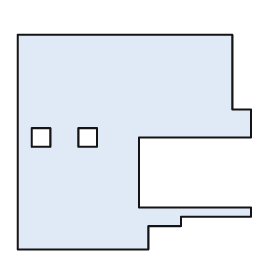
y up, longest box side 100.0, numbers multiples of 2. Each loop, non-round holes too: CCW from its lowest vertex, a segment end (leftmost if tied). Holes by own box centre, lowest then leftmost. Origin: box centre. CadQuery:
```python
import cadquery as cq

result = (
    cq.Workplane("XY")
    .moveTo(-50.0, -46.0)
    .lineTo(6.0, -46.0)
    .lineTo(6.0, -36.0)
    .lineTo(20.0, -36.0)
    .lineTo(20.0, -32.0)
    .lineTo(50.0, -32.0)
    .lineTo(50.0, -28.0)
    .lineTo(2.0, -28.0)
    .lineTo(2.0, 2.0)
    .lineTo(50.0, 2.0)
    .lineTo(50.0, 14.0)
    .lineTo(42.0, 14.0)
    .lineTo(42.0, 46.0)
    .lineTo(-50.0, 46.0)
    .close()
    .moveTo(-44.0, -2.0)
    .lineTo(-36.0, -2.0)
    .lineTo(-36.0, 6.0)
    .lineTo(-44.0, 6.0)
    .close()
    .moveTo(-24.0, -2.0)
    .lineTo(-16.0, -2.0)
    .lineTo(-16.0, 6.0)
    .lineTo(-24.0, 6.0)
    .close()
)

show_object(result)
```